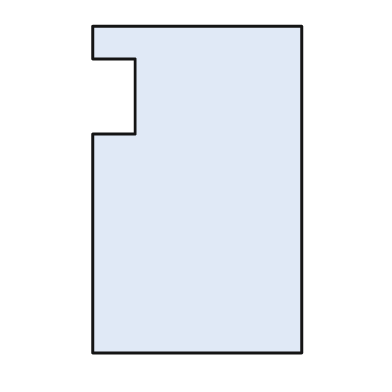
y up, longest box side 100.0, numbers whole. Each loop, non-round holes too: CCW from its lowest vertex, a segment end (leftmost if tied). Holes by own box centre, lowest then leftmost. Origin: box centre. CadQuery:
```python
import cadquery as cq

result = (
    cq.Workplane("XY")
    .moveTo(-32.0, -50.0)
    .lineTo(32.0, -50.0)
    .lineTo(32.0, 50.0)
    .lineTo(-32.0, 50.0)
    .lineTo(-32.0, 40.0)
    .lineTo(-19.0, 40.0)
    .lineTo(-19.0, 17.0)
    .lineTo(-32.0, 17.0)
    .close()
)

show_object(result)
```